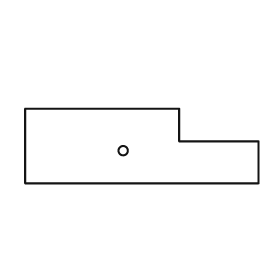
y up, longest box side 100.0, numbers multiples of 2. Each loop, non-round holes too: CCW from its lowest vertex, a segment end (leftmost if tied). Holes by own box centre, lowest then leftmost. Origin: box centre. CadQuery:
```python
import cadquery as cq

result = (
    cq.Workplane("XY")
    .moveTo(-50.0, -16.0)
    .lineTo(50.0, -16.0)
    .lineTo(50.0, 2.0)
    .lineTo(16.0, 2.0)
    .lineTo(16.0, 16.0)
    .lineTo(-50.0, 16.0)
    .close()
    .moveTo(-8.0, -2.0)
    .circle(2.0)
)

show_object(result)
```